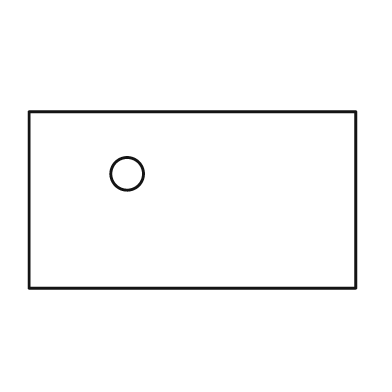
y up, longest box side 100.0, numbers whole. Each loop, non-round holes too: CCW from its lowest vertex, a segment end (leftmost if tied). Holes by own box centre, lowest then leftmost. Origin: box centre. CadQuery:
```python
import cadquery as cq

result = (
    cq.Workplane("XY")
    .moveTo(-50.0, -27.0)
    .lineTo(50.0, -27.0)
    .lineTo(50.0, 27.0)
    .lineTo(-50.0, 27.0)
    .close()
    .moveTo(-20.0, 8.0)
    .circle(5.0)
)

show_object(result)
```